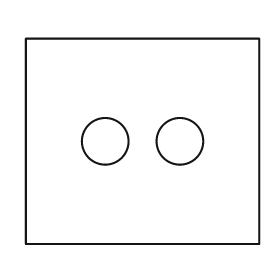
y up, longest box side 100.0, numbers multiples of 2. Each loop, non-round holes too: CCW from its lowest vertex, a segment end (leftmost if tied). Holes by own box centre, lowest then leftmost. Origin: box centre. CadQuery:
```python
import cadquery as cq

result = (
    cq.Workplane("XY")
    .moveTo(-50.0, -44.0)
    .lineTo(50.0, -44.0)
    .lineTo(50.0, 44.0)
    .lineTo(-50.0, 44.0)
    .close()
    .moveTo(-16.0, 0.0)
    .circle(10.0)
    .moveTo(16.0, 0.0)
    .circle(10.0)
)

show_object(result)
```